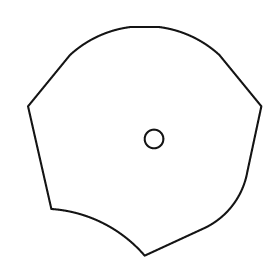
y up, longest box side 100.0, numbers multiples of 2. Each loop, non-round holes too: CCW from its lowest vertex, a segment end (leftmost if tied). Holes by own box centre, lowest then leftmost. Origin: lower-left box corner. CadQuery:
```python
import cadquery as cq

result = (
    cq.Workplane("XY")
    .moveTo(50.0, 0.0)
    .lineTo(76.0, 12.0)
    .threePointArc((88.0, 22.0), (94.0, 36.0))
    .lineTo(100.0, 64.0)
    .lineTo(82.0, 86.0)
    .threePointArc((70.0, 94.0), (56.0, 98.0))
    .lineTo(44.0, 98.0)
    .threePointArc((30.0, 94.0), (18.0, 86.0))
    .lineTo(0.0, 64.0)
    .lineTo(10.0, 20.0)
    .threePointArc((32.0, 14.0), (50.0, 0.0))
    .close()
    .moveTo(54.0, 50.0)
    .circle(4.0)
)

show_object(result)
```